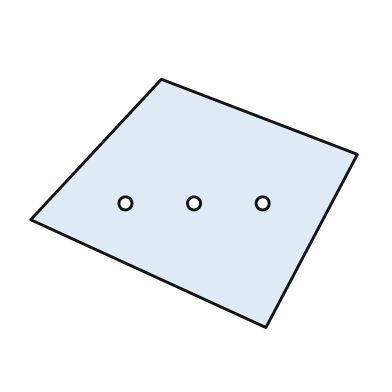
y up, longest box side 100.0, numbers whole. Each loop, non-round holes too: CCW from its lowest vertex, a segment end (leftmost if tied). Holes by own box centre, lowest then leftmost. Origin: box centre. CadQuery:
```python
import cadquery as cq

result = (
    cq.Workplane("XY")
    .moveTo(22.0, -38.0)
    .lineTo(50.0, 15.0)
    .lineTo(-10.0, 38.0)
    .lineTo(-50.0, -5.0)
    .close()
    .moveTo(-21.0, 0.0)
    .circle(2.0)
    .moveTo(0.0, 0.0)
    .circle(2.0)
    .moveTo(21.0, 0.0)
    .circle(2.0)
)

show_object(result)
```